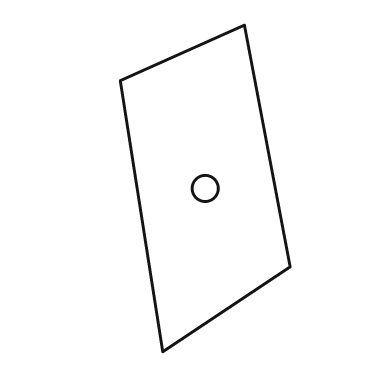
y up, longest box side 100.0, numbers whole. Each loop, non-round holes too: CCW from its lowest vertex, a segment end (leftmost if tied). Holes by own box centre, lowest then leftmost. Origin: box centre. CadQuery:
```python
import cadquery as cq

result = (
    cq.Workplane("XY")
    .moveTo(-13.0, -50.0)
    .lineTo(26.0, -24.0)
    .lineTo(12.0, 50.0)
    .lineTo(-26.0, 33.0)
    .close()
    .moveTo(0.0, 0.0)
    .circle(4.0)
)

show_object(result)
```